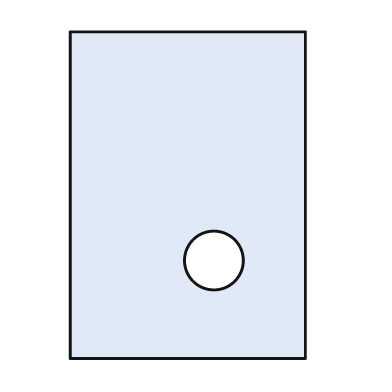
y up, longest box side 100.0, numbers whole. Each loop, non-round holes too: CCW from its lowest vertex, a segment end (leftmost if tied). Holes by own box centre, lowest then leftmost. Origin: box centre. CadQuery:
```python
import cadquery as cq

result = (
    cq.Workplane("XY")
    .moveTo(-36.0, -50.0)
    .lineTo(36.0, -50.0)
    .lineTo(36.0, 50.0)
    .lineTo(-36.0, 50.0)
    .close()
    .moveTo(8.0, -20.0)
    .circle(9.0)
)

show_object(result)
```